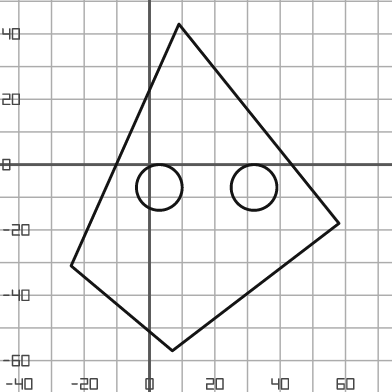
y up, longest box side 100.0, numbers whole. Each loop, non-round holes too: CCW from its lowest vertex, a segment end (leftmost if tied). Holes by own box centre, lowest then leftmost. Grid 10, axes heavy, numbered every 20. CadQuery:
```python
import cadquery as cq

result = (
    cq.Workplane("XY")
    .moveTo(7.0, -57.0)
    .lineTo(58.0, -18.0)
    .lineTo(9.0, 43.0)
    .lineTo(-24.0, -31.0)
    .close()
    .moveTo(3.0, -7.0)
    .circle(7.0)
    .moveTo(32.0, -7.0)
    .circle(7.0)
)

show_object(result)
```